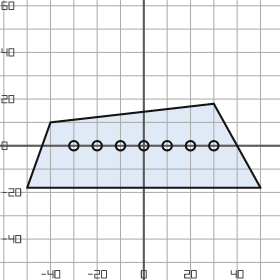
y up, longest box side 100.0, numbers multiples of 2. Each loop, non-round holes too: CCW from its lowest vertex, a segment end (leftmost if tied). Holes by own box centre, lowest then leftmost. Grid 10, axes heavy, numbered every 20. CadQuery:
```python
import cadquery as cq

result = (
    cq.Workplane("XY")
    .moveTo(-50.0, -18.0)
    .lineTo(50.0, -18.0)
    .lineTo(30.0, 18.0)
    .lineTo(-40.0, 10.0)
    .close()
    .moveTo(-30.0, 0.0)
    .circle(2.0)
    .moveTo(-20.0, 0.0)
    .circle(2.0)
    .moveTo(-10.0, 0.0)
    .circle(2.0)
    .moveTo(0.0, 0.0)
    .circle(2.0)
    .moveTo(10.0, 0.0)
    .circle(2.0)
    .moveTo(20.0, 0.0)
    .circle(2.0)
    .moveTo(30.0, 0.0)
    .circle(2.0)
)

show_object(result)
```